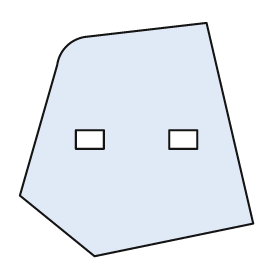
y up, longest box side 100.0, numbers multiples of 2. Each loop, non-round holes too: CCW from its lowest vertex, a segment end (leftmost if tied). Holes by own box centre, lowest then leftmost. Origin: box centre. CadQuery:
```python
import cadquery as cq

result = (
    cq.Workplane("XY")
    .moveTo(-18.0, -50.0)
    .lineTo(50.0, -36.0)
    .lineTo(30.0, 50.0)
    .lineTo(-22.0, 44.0)
    .threePointArc((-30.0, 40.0), (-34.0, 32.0))
    .lineTo(-50.0, -24.0)
    .close()
    .moveTo(-26.0, -4.0)
    .lineTo(-14.0, -4.0)
    .lineTo(-14.0, 4.0)
    .lineTo(-26.0, 4.0)
    .close()
    .moveTo(14.0, -4.0)
    .lineTo(26.0, -4.0)
    .lineTo(26.0, 4.0)
    .lineTo(14.0, 4.0)
    .close()
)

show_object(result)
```